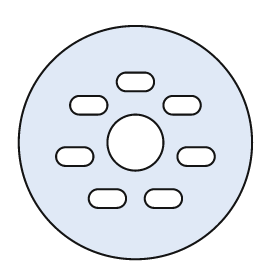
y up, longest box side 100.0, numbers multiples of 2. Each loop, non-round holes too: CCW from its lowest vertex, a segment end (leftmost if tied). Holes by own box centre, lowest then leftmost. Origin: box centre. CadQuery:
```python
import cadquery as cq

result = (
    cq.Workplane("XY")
    .moveTo(0.0, 0.0)
    .circle(50.0)
    .moveTo(-16.0, -28.0)
    .lineTo(-8.0, -28.0)
    .threePointArc((-4.0, -24.0), (-8.0, -20.0))
    .lineTo(-16.0, -20.0)
    .threePointArc((-20.0, -24.0), (-16.0, -28.0))
    .close()
    .moveTo(8.0, -28.0)
    .lineTo(16.0, -28.0)
    .threePointArc((20.0, -24.0), (16.0, -20.0))
    .lineTo(8.0, -20.0)
    .threePointArc((4.0, -24.0), (8.0, -28.0))
    .close()
    .moveTo(-30.0, -10.0)
    .lineTo(-22.0, -10.0)
    .threePointArc((-18.0, -6.0), (-22.0, -2.0))
    .lineTo(-30.0, -2.0)
    .threePointArc((-34.0, -6.0), (-30.0, -10.0))
    .close()
    .moveTo(22.0, -10.0)
    .lineTo(30.0, -10.0)
    .threePointArc((34.0, -6.0), (30.0, -2.0))
    .lineTo(22.0, -2.0)
    .threePointArc((18.0, -6.0), (22.0, -10.0))
    .close()
    .moveTo(0.0, 0.0)
    .circle(12.0)
    .moveTo(-24.0, 12.0)
    .lineTo(-16.0, 12.0)
    .threePointArc((-12.0, 16.0), (-16.0, 20.0))
    .lineTo(-24.0, 20.0)
    .threePointArc((-28.0, 16.0), (-24.0, 12.0))
    .close()
    .moveTo(16.0, 12.0)
    .lineTo(24.0, 12.0)
    .threePointArc((28.0, 16.0), (24.0, 20.0))
    .lineTo(16.0, 20.0)
    .threePointArc((12.0, 16.0), (16.0, 12.0))
    .close()
    .moveTo(-4.0, 22.0)
    .lineTo(4.0, 22.0)
    .threePointArc((8.0, 26.0), (4.0, 30.0))
    .lineTo(-4.0, 30.0)
    .threePointArc((-8.0, 26.0), (-4.0, 22.0))
    .close()
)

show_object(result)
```